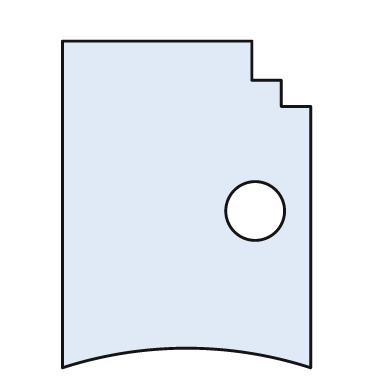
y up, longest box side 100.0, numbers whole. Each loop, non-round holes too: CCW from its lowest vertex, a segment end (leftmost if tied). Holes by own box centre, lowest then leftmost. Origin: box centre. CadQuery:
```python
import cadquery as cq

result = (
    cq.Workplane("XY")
    .moveTo(-38.0, -50.0)
    .threePointArc((0.0, -44.0), (38.0, -50.0))
    .lineTo(38.0, 30.0)
    .lineTo(29.0, 30.0)
    .lineTo(29.0, 38.0)
    .lineTo(20.0, 38.0)
    .lineTo(20.0, 50.0)
    .lineTo(-38.0, 50.0)
    .close()
    .moveTo(21.0, -2.0)
    .circle(9.0)
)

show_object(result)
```